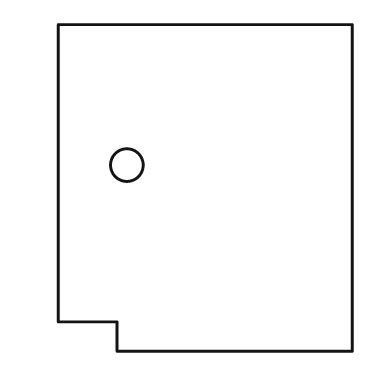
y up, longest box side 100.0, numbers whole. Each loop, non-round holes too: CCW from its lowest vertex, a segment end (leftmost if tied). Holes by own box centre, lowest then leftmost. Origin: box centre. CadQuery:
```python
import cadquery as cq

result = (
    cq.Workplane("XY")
    .moveTo(-27.0, -50.0)
    .lineTo(45.0, -50.0)
    .lineTo(45.0, 50.0)
    .lineTo(-45.0, 50.0)
    .lineTo(-45.0, -41.0)
    .lineTo(-27.0, -41.0)
    .close()
    .moveTo(-24.0, 7.0)
    .circle(5.0)
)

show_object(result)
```